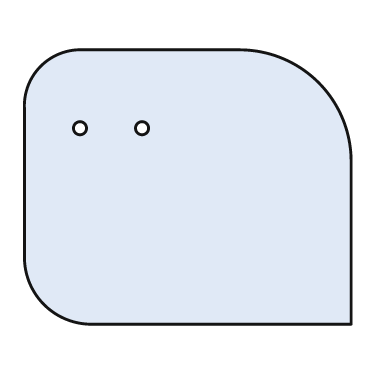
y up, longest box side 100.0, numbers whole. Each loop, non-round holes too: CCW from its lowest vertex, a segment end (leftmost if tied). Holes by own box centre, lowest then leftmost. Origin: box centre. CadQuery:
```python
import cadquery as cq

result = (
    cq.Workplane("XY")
    .moveTo(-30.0, -42.0)
    .lineTo(50.0, -42.0)
    .lineTo(50.0, 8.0)
    .threePointArc((40.0, 32.0), (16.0, 42.0))
    .lineTo(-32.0, 42.0)
    .threePointArc((-45.0, 37.0), (-50.0, 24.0))
    .lineTo(-50.0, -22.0)
    .threePointArc((-44.0, -36.0), (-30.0, -42.0))
    .close()
    .moveTo(-33.0, 18.0)
    .circle(2.0)
    .moveTo(-14.0, 18.0)
    .circle(2.0)
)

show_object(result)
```